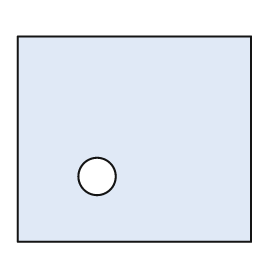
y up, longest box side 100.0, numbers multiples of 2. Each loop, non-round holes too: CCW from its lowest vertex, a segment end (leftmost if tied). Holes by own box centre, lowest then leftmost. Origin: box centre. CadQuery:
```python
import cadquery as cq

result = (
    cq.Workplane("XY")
    .moveTo(-50.0, -44.0)
    .lineTo(50.0, -44.0)
    .lineTo(50.0, 44.0)
    .lineTo(-50.0, 44.0)
    .close()
    .moveTo(-16.0, -16.0)
    .circle(8.0)
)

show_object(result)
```